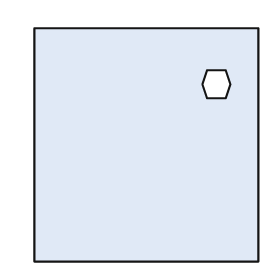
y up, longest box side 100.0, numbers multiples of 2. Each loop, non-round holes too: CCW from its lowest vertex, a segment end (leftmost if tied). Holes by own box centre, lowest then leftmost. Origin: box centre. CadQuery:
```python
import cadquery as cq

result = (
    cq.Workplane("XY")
    .moveTo(-48.0, -50.0)
    .lineTo(48.0, -50.0)
    .lineTo(48.0, 50.0)
    .lineTo(-48.0, 50.0)
    .close()
    .moveTo(26.0, 20.0)
    .lineTo(34.0, 20.0)
    .lineTo(36.0, 26.0)
    .lineTo(34.0, 32.0)
    .lineTo(26.0, 32.0)
    .lineTo(24.0, 26.0)
    .close()
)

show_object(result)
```